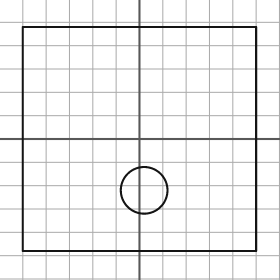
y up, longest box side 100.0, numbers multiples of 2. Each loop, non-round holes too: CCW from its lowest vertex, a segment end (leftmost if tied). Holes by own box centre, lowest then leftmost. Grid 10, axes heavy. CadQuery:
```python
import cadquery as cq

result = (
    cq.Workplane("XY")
    .moveTo(-50.0, -48.0)
    .lineTo(50.0, -48.0)
    .lineTo(50.0, 48.0)
    .lineTo(-50.0, 48.0)
    .close()
    .moveTo(2.0, -22.0)
    .circle(10.0)
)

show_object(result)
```